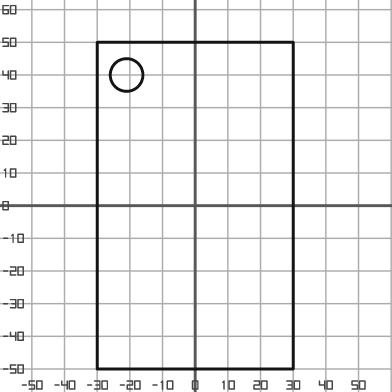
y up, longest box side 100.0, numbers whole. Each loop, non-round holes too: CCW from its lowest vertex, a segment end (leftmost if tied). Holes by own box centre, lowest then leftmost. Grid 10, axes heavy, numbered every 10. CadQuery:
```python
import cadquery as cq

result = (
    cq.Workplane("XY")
    .moveTo(-30.0, -50.0)
    .lineTo(30.0, -50.0)
    .lineTo(30.0, 50.0)
    .lineTo(-30.0, 50.0)
    .close()
    .moveTo(-21.0, 40.0)
    .circle(5.0)
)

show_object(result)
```